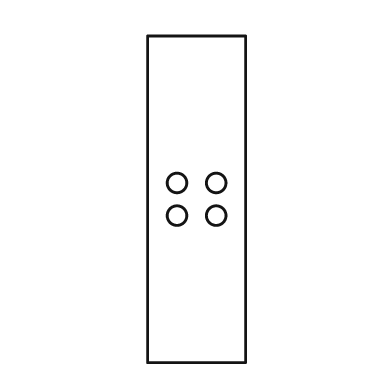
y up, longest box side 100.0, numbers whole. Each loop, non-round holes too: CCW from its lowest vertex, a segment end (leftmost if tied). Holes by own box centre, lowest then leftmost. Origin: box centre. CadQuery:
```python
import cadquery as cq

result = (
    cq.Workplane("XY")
    .moveTo(-15.0, -50.0)
    .lineTo(15.0, -50.0)
    .lineTo(15.0, 50.0)
    .lineTo(-15.0, 50.0)
    .close()
    .moveTo(-6.0, -5.0)
    .circle(3.0)
    .moveTo(6.0, -5.0)
    .circle(3.0)
    .moveTo(-6.0, 5.0)
    .circle(3.0)
    .moveTo(6.0, 5.0)
    .circle(3.0)
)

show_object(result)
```